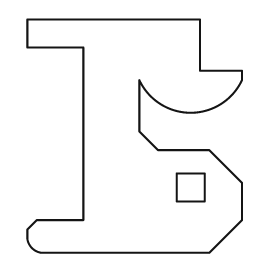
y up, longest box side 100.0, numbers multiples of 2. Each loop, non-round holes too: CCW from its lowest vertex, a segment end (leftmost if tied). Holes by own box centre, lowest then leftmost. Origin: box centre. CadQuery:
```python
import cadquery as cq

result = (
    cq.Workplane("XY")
    .moveTo(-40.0, -50.0)
    .lineTo(32.0, -50.0)
    .lineTo(46.0, -36.0)
    .lineTo(46.0, -20.0)
    .lineTo(32.0, -6.0)
    .lineTo(10.0, -6.0)
    .lineTo(2.0, 2.0)
    .lineTo(2.0, 24.0)
    .threePointArc((24.0, 10.0), (46.0, 24.0))
    .lineTo(46.0, 28.0)
    .lineTo(28.0, 28.0)
    .lineTo(28.0, 50.0)
    .lineTo(-46.0, 50.0)
    .lineTo(-46.0, 38.0)
    .lineTo(-22.0, 38.0)
    .lineTo(-22.0, -36.0)
    .lineTo(-42.0, -36.0)
    .lineTo(-46.0, -40.0)
    .lineTo(-46.0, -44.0)
    .threePointArc((-44.0, -48.0), (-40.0, -50.0))
    .close()
    .moveTo(18.0, -28.0)
    .lineTo(30.0, -28.0)
    .lineTo(30.0, -16.0)
    .lineTo(18.0, -16.0)
    .close()
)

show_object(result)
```